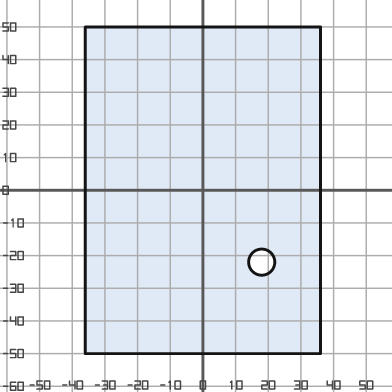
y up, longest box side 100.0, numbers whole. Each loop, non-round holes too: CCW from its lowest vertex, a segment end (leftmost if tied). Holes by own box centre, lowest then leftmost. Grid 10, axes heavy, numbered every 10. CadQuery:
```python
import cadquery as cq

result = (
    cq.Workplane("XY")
    .moveTo(-36.0, -50.0)
    .lineTo(36.0, -50.0)
    .lineTo(36.0, 50.0)
    .lineTo(-36.0, 50.0)
    .close()
    .moveTo(18.0, -22.0)
    .circle(4.0)
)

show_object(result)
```